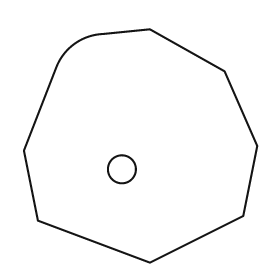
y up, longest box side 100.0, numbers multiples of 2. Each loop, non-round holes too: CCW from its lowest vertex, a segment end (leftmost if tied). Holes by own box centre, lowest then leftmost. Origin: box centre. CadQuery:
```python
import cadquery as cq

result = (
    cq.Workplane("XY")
    .moveTo(4.0, -50.0)
    .lineTo(44.0, -30.0)
    .lineTo(50.0, 0.0)
    .lineTo(36.0, 32.0)
    .lineTo(4.0, 50.0)
    .lineTo(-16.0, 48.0)
    .threePointArc((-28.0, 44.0), (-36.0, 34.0))
    .lineTo(-50.0, -2.0)
    .lineTo(-44.0, -32.0)
    .close()
    .moveTo(-8.0, -10.0)
    .circle(6.0)
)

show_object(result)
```